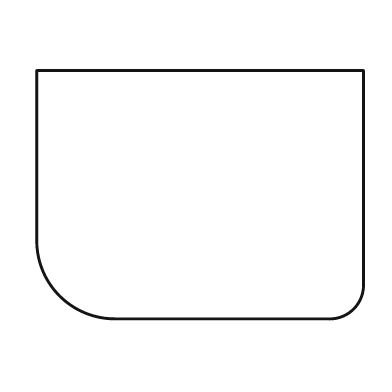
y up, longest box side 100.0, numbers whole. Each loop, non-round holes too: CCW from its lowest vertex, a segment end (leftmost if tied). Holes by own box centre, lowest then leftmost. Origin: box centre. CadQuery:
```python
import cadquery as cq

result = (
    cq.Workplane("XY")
    .moveTo(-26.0, -38.0)
    .lineTo(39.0, -38.0)
    .threePointArc((47.0, -35.0), (50.0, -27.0))
    .lineTo(50.0, 38.0)
    .lineTo(-50.0, 38.0)
    .lineTo(-50.0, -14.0)
    .threePointArc((-43.0, -31.0), (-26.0, -38.0))
    .close()
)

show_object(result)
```